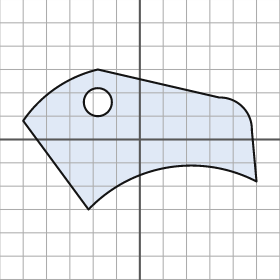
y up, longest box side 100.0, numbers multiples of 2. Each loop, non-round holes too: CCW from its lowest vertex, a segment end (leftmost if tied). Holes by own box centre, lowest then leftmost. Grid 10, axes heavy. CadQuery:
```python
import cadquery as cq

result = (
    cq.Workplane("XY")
    .moveTo(-22.0, -30.0)
    .threePointArc((12.0, -12.0), (50.0, -18.0))
    .lineTo(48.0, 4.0)
    .threePointArc((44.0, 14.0), (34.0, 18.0))
    .lineTo(-18.0, 30.0)
    .threePointArc((-36.0, 22.0), (-50.0, 8.0))
    .close()
    .moveTo(-18.0, 16.0)
    .circle(6.0)
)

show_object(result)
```